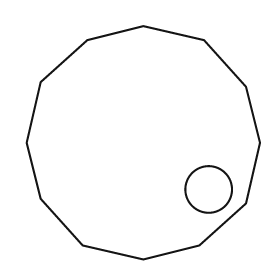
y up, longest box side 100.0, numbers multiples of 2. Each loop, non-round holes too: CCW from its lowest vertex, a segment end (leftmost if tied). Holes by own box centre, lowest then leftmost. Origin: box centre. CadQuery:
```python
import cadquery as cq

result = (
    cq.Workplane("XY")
    .moveTo(0.0, -50.0)
    .lineTo(24.0, -44.0)
    .lineTo(44.0, -26.0)
    .lineTo(50.0, 0.0)
    .lineTo(44.0, 24.0)
    .lineTo(26.0, 44.0)
    .lineTo(0.0, 50.0)
    .lineTo(-24.0, 44.0)
    .lineTo(-44.0, 26.0)
    .lineTo(-50.0, 0.0)
    .lineTo(-44.0, -24.0)
    .lineTo(-26.0, -44.0)
    .close()
    .moveTo(28.0, -20.0)
    .circle(10.0)
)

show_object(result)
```